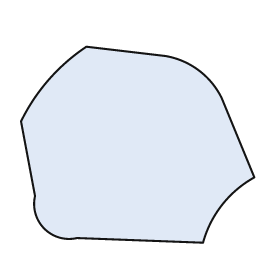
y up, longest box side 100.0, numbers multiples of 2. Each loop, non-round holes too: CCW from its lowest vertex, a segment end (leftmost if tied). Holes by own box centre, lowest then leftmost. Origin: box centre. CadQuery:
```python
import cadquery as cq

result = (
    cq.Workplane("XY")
    .moveTo(28.0, -42.0)
    .threePointArc((36.0, -26.0), (50.0, -14.0))
    .lineTo(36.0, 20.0)
    .threePointArc((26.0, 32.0), (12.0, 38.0))
    .lineTo(-22.0, 42.0)
    .threePointArc((-38.0, 28.0), (-50.0, 10.0))
    .lineTo(-44.0, -22.0)
    .threePointArc((-40.0, -36.0), (-26.0, -40.0))
    .close()
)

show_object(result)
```